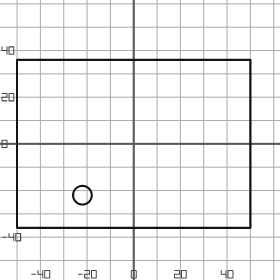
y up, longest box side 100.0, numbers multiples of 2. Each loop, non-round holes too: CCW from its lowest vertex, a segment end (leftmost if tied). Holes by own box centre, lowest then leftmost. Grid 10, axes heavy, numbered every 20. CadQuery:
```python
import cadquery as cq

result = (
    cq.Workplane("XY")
    .moveTo(-50.0, -36.0)
    .lineTo(50.0, -36.0)
    .lineTo(50.0, 36.0)
    .lineTo(-50.0, 36.0)
    .close()
    .moveTo(-22.0, -22.0)
    .circle(4.0)
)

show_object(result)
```